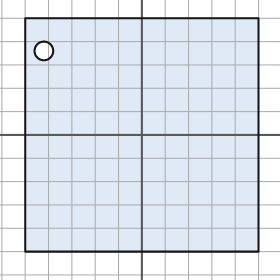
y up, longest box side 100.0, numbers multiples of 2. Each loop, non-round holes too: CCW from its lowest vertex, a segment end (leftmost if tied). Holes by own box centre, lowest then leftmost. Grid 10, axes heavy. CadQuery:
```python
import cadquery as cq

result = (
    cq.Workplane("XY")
    .moveTo(-50.0, -50.0)
    .lineTo(50.0, -50.0)
    .lineTo(50.0, 50.0)
    .lineTo(-50.0, 50.0)
    .close()
    .moveTo(-42.0, 36.0)
    .circle(4.0)
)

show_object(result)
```